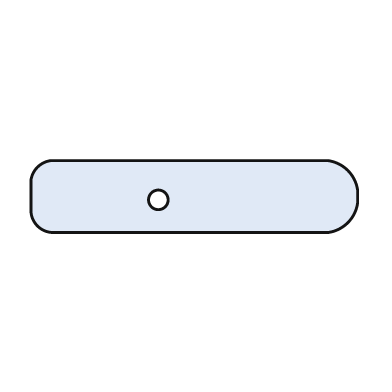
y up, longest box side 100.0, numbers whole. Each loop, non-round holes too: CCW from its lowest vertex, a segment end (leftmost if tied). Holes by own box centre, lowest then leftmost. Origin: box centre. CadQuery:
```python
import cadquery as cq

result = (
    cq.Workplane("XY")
    .moveTo(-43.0, -11.0)
    .lineTo(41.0, -11.0)
    .threePointArc((47.0, -8.0), (50.0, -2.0))
    .lineTo(50.0, 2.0)
    .threePointArc((47.0, 8.0), (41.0, 11.0))
    .lineTo(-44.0, 11.0)
    .threePointArc((-48.0, 9.0), (-50.0, 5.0))
    .lineTo(-50.0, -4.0)
    .threePointArc((-48.0, -9.0), (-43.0, -11.0))
    .close()
    .moveTo(-11.0, -1.0)
    .circle(3.0)
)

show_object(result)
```